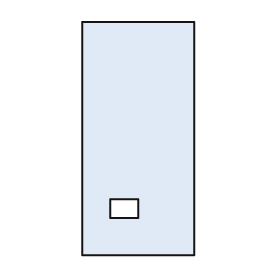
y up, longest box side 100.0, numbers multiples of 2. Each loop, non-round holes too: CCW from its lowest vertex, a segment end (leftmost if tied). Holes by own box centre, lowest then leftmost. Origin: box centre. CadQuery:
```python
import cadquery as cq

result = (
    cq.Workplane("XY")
    .moveTo(-24.0, -50.0)
    .lineTo(24.0, -50.0)
    .lineTo(24.0, 50.0)
    .lineTo(-24.0, 50.0)
    .close()
    .moveTo(-12.0, -34.0)
    .lineTo(0.0, -34.0)
    .lineTo(0.0, -26.0)
    .lineTo(-12.0, -26.0)
    .close()
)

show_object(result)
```